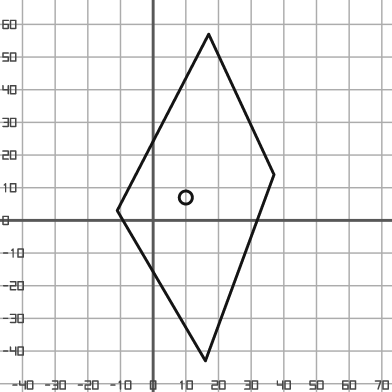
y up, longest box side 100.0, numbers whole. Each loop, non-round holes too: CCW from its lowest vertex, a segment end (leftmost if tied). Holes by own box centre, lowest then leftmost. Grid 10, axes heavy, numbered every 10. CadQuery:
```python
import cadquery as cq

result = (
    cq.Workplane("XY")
    .moveTo(16.0, -43.0)
    .lineTo(37.0, 14.0)
    .lineTo(17.0, 57.0)
    .lineTo(-11.0, 3.0)
    .close()
    .moveTo(10.0, 7.0)
    .circle(2.0)
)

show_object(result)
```